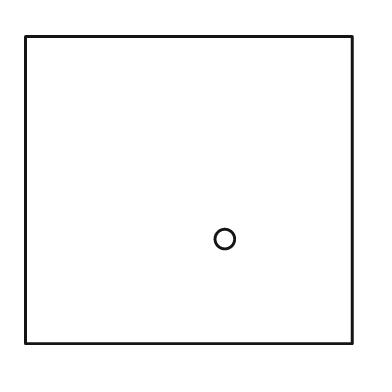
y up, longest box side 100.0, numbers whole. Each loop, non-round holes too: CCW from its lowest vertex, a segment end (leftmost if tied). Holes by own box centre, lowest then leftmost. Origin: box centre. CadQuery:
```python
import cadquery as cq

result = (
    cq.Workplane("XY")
    .moveTo(-50.0, -47.0)
    .lineTo(50.0, -47.0)
    .lineTo(50.0, 47.0)
    .lineTo(-50.0, 47.0)
    .close()
    .moveTo(11.0, -15.0)
    .circle(3.0)
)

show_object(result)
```